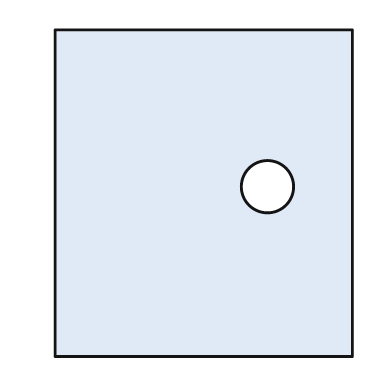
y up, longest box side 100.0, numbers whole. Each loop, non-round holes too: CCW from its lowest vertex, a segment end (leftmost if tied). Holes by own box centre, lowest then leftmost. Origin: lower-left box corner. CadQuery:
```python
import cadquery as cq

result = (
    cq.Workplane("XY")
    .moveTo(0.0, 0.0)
    .lineTo(91.0, 0.0)
    .lineTo(91.0, 100.0)
    .lineTo(0.0, 100.0)
    .close()
    .moveTo(65.0, 52.0)
    .circle(8.0)
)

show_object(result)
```